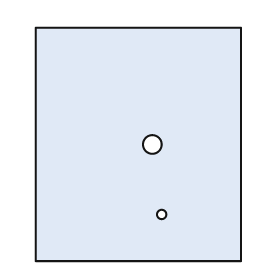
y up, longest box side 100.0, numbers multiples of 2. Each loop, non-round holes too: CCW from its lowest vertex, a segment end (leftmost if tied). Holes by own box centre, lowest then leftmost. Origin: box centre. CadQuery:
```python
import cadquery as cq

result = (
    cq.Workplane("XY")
    .moveTo(-44.0, -50.0)
    .lineTo(44.0, -50.0)
    .lineTo(44.0, 50.0)
    .lineTo(-44.0, 50.0)
    .close()
    .moveTo(10.0, -30.0)
    .circle(2.0)
    .moveTo(6.0, 0.0)
    .circle(4.0)
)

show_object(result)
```